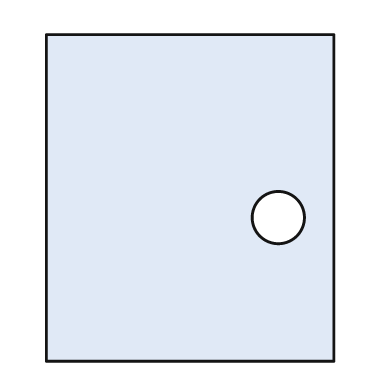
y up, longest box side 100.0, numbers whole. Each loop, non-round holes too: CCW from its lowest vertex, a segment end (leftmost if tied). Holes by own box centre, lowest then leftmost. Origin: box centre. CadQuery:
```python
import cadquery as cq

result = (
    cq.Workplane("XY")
    .moveTo(-44.0, -50.0)
    .lineTo(44.0, -50.0)
    .lineTo(44.0, 50.0)
    .lineTo(-44.0, 50.0)
    .close()
    .moveTo(27.0, -6.0)
    .circle(8.0)
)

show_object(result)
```